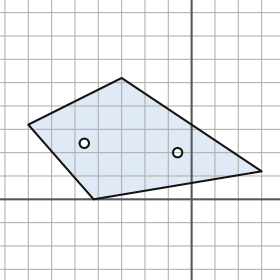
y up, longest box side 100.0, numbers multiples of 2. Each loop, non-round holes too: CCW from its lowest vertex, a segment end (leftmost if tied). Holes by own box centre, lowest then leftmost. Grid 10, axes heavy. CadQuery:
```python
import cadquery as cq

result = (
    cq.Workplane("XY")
    .moveTo(-42.0, 0.0)
    .lineTo(30.0, 12.0)
    .lineTo(-30.0, 52.0)
    .lineTo(-70.0, 32.0)
    .close()
    .moveTo(-6.0, 20.0)
    .circle(2.0)
    .moveTo(-46.0, 24.0)
    .circle(2.0)
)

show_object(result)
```